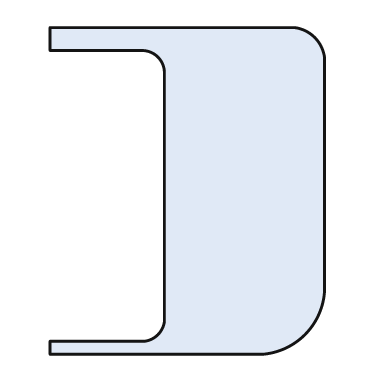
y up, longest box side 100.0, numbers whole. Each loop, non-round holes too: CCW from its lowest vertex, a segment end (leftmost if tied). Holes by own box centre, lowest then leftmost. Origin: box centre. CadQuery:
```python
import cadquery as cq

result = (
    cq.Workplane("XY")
    .moveTo(-42.0, -50.0)
    .lineTo(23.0, -50.0)
    .threePointArc((36.0, -44.0), (42.0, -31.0))
    .lineTo(42.0, 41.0)
    .threePointArc((39.0, 47.0), (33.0, 50.0))
    .lineTo(-42.0, 50.0)
    .lineTo(-42.0, 43.0)
    .lineTo(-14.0, 43.0)
    .threePointArc((-9.0, 41.0), (-7.0, 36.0))
    .lineTo(-7.0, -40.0)
    .threePointArc((-9.0, -44.0), (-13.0, -46.0))
    .lineTo(-42.0, -46.0)
    .close()
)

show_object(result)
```